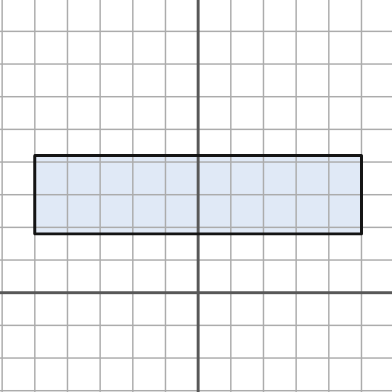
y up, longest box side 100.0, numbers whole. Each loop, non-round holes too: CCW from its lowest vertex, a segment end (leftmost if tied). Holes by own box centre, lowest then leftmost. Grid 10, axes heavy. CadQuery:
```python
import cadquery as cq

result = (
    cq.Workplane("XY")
    .moveTo(-50.0, 18.0)
    .lineTo(50.0, 18.0)
    .lineTo(50.0, 42.0)
    .lineTo(-50.0, 42.0)
    .close()
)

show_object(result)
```